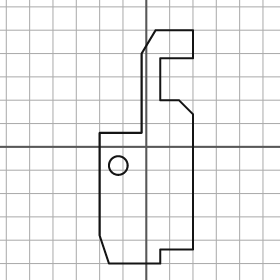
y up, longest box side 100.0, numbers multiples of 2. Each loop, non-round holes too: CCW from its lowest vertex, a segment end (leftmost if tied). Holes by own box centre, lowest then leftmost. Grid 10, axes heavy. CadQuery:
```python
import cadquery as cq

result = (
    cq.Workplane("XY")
    .moveTo(-16.0, -50.0)
    .lineTo(6.0, -50.0)
    .lineTo(6.0, -44.0)
    .lineTo(20.0, -44.0)
    .lineTo(20.0, 14.0)
    .lineTo(14.0, 20.0)
    .lineTo(6.0, 20.0)
    .lineTo(6.0, 38.0)
    .lineTo(20.0, 38.0)
    .lineTo(20.0, 50.0)
    .lineTo(4.0, 50.0)
    .lineTo(-2.0, 40.0)
    .lineTo(-2.0, 6.0)
    .lineTo(-20.0, 6.0)
    .lineTo(-20.0, -38.0)
    .close()
    .moveTo(-12.0, -8.0)
    .circle(4.0)
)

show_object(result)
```